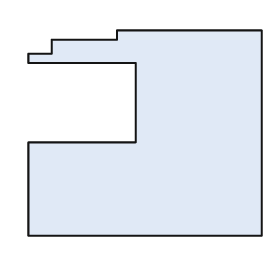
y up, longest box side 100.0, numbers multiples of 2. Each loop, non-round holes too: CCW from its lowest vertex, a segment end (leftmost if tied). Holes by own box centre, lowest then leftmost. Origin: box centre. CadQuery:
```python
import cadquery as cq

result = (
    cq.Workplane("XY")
    .moveTo(-50.0, -44.0)
    .lineTo(50.0, -44.0)
    .lineTo(50.0, 44.0)
    .lineTo(-12.0, 44.0)
    .lineTo(-12.0, 40.0)
    .lineTo(-40.0, 40.0)
    .lineTo(-40.0, 34.0)
    .lineTo(-50.0, 34.0)
    .lineTo(-50.0, 30.0)
    .lineTo(-4.0, 30.0)
    .lineTo(-4.0, -4.0)
    .lineTo(-50.0, -4.0)
    .close()
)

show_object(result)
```